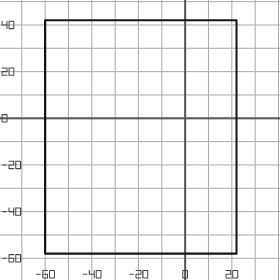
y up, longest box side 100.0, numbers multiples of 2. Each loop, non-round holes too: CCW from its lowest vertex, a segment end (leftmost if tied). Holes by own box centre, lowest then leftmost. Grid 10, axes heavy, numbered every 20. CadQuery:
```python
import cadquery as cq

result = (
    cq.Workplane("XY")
    .moveTo(-60.0, -58.0)
    .lineTo(22.0, -58.0)
    .lineTo(22.0, 42.0)
    .lineTo(-60.0, 42.0)
    .close()
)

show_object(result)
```